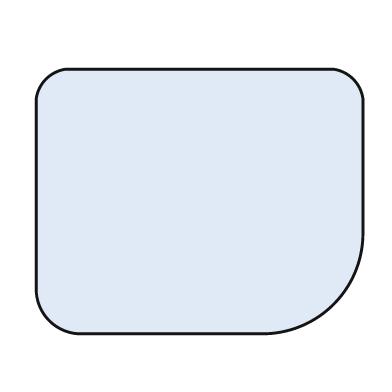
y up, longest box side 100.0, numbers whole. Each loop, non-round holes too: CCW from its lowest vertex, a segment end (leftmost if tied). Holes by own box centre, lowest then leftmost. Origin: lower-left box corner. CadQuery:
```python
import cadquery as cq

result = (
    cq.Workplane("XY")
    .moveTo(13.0, 0.0)
    .lineTo(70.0, 0.0)
    .threePointArc((91.0, 9.0), (100.0, 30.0))
    .lineTo(100.0, 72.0)
    .threePointArc((97.0, 78.0), (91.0, 81.0))
    .lineTo(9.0, 81.0)
    .threePointArc((3.0, 78.0), (0.0, 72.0))
    .lineTo(0.0, 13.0)
    .threePointArc((4.0, 4.0), (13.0, 0.0))
    .close()
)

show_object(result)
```